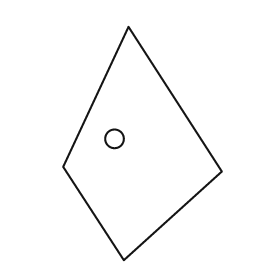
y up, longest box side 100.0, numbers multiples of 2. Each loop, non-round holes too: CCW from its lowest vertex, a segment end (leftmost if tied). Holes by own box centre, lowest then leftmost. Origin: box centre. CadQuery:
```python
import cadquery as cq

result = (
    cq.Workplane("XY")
    .moveTo(-8.0, -50.0)
    .lineTo(34.0, -12.0)
    .lineTo(-6.0, 50.0)
    .lineTo(-34.0, -10.0)
    .close()
    .moveTo(-12.0, 2.0)
    .circle(4.0)
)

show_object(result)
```